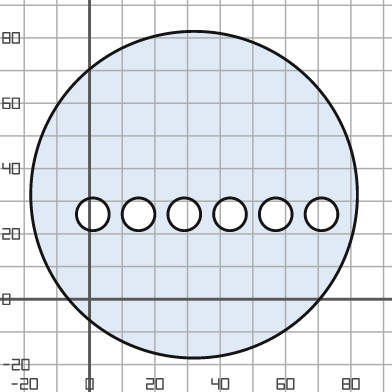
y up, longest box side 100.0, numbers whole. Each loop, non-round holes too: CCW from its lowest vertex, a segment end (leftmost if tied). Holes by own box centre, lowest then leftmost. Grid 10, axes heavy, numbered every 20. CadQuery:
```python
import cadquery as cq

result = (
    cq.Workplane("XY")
    .moveTo(32.0, 32.0)
    .circle(50.0)
    .moveTo(1.0, 26.0)
    .circle(5.0)
    .moveTo(15.0, 26.0)
    .circle(5.0)
    .moveTo(29.0, 26.0)
    .circle(5.0)
    .moveTo(43.0, 26.0)
    .circle(5.0)
    .moveTo(57.0, 26.0)
    .circle(5.0)
    .moveTo(71.0, 26.0)
    .circle(5.0)
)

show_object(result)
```